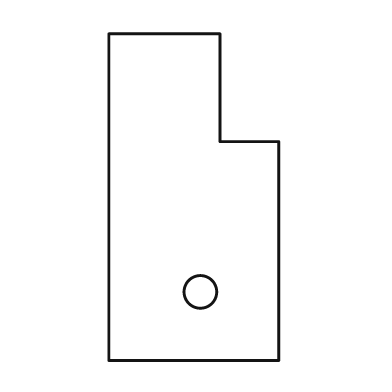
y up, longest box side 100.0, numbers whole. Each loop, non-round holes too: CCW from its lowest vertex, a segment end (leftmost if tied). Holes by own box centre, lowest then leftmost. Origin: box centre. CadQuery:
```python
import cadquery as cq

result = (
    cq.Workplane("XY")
    .moveTo(-26.0, -50.0)
    .lineTo(26.0, -50.0)
    .lineTo(26.0, 17.0)
    .lineTo(8.0, 17.0)
    .lineTo(8.0, 50.0)
    .lineTo(-26.0, 50.0)
    .close()
    .moveTo(2.0, -29.0)
    .circle(5.0)
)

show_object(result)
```